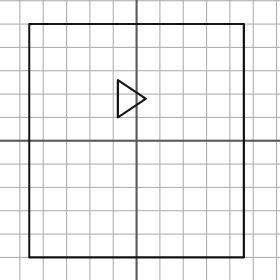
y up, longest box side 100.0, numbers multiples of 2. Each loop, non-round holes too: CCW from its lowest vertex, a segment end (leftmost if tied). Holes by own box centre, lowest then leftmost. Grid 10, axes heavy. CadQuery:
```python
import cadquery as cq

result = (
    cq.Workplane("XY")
    .moveTo(-46.0, -50.0)
    .lineTo(46.0, -50.0)
    .lineTo(46.0, 50.0)
    .lineTo(-46.0, 50.0)
    .close()
    .moveTo(-8.0, 10.0)
    .lineTo(4.0, 18.0)
    .lineTo(-8.0, 26.0)
    .close()
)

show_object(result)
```